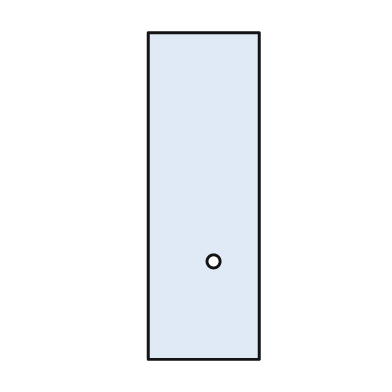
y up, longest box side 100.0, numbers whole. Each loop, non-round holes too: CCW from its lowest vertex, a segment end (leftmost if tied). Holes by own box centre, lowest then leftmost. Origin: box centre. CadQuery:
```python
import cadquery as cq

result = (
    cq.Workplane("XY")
    .moveTo(-17.0, -50.0)
    .lineTo(17.0, -50.0)
    .lineTo(17.0, 50.0)
    .lineTo(-17.0, 50.0)
    .close()
    .moveTo(3.0, -20.0)
    .circle(2.0)
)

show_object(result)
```